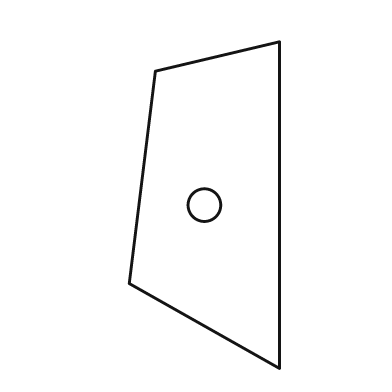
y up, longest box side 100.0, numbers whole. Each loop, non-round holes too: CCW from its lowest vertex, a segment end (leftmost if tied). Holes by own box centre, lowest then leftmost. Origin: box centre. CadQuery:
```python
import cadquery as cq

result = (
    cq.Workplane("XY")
    .moveTo(23.0, -50.0)
    .lineTo(23.0, 50.0)
    .lineTo(-15.0, 41.0)
    .lineTo(-23.0, -24.0)
    .close()
    .moveTo(0.0, 0.0)
    .circle(5.0)
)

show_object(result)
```